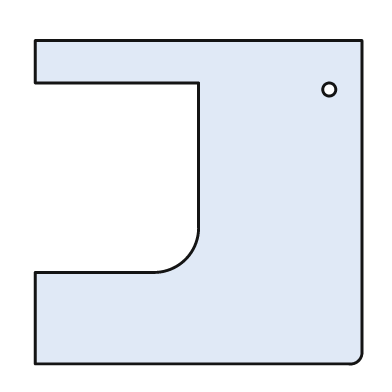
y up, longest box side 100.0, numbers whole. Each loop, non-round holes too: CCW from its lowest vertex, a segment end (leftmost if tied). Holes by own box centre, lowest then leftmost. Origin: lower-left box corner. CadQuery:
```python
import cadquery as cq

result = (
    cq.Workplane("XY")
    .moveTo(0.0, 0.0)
    .lineTo(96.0, 0.0)
    .threePointArc((99.0, 1.0), (100.0, 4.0))
    .lineTo(100.0, 99.0)
    .lineTo(0.0, 99.0)
    .lineTo(0.0, 86.0)
    .lineTo(50.0, 86.0)
    .lineTo(50.0, 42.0)
    .threePointArc((46.0, 32.0), (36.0, 28.0))
    .lineTo(0.0, 28.0)
    .close()
    .moveTo(90.0, 84.0)
    .circle(2.0)
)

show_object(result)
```